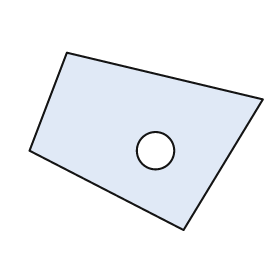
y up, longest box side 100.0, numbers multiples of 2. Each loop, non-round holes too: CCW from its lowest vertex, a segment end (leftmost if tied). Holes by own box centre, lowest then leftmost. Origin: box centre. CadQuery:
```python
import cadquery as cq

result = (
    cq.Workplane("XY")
    .moveTo(16.0, -38.0)
    .lineTo(50.0, 18.0)
    .lineTo(-34.0, 38.0)
    .lineTo(-50.0, -4.0)
    .close()
    .moveTo(4.0, -4.0)
    .circle(8.0)
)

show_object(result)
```